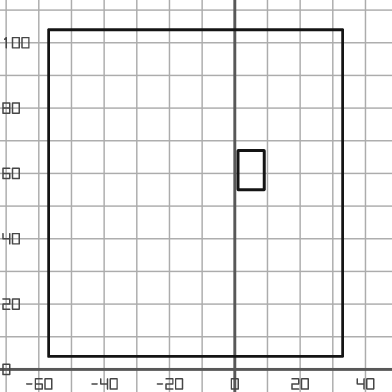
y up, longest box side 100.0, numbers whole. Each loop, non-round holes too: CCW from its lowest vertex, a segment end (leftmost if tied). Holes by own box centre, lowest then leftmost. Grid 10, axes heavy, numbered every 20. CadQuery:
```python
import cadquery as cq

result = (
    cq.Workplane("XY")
    .moveTo(-57.0, 4.0)
    .lineTo(33.0, 4.0)
    .lineTo(33.0, 104.0)
    .lineTo(-57.0, 104.0)
    .close()
    .moveTo(1.0, 55.0)
    .lineTo(9.0, 55.0)
    .lineTo(9.0, 67.0)
    .lineTo(1.0, 67.0)
    .close()
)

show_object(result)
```